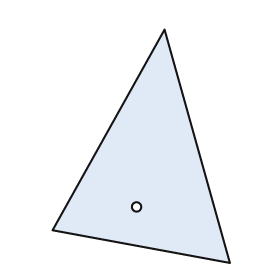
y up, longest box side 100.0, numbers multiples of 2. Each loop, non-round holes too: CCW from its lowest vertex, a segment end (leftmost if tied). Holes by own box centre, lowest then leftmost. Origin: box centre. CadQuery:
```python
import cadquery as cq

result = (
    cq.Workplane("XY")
    .moveTo(38.0, -50.0)
    .lineTo(10.0, 50.0)
    .lineTo(-38.0, -36.0)
    .close()
    .moveTo(-2.0, -26.0)
    .circle(2.0)
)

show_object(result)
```